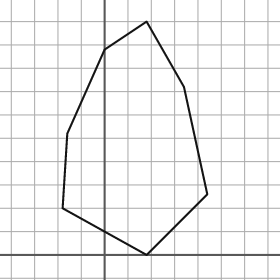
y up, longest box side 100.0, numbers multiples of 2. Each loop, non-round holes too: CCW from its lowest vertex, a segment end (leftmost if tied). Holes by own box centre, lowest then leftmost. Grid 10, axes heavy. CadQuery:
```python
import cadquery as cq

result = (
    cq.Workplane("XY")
    .moveTo(18.0, 0.0)
    .lineTo(44.0, 26.0)
    .lineTo(34.0, 72.0)
    .lineTo(18.0, 100.0)
    .lineTo(0.0, 88.0)
    .lineTo(-16.0, 52.0)
    .lineTo(-18.0, 20.0)
    .close()
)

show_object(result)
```